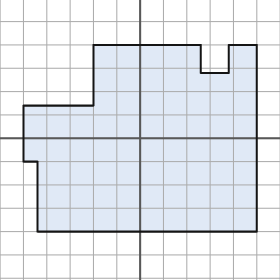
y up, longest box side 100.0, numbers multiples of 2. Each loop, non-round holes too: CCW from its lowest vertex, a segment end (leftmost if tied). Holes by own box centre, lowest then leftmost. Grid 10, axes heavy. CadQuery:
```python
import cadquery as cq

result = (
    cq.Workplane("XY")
    .moveTo(-44.0, -40.0)
    .lineTo(50.0, -40.0)
    .lineTo(50.0, 40.0)
    .lineTo(38.0, 40.0)
    .lineTo(38.0, 28.0)
    .lineTo(26.0, 28.0)
    .lineTo(26.0, 40.0)
    .lineTo(-20.0, 40.0)
    .lineTo(-20.0, 14.0)
    .lineTo(-50.0, 14.0)
    .lineTo(-50.0, -10.0)
    .lineTo(-44.0, -10.0)
    .close()
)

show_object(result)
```